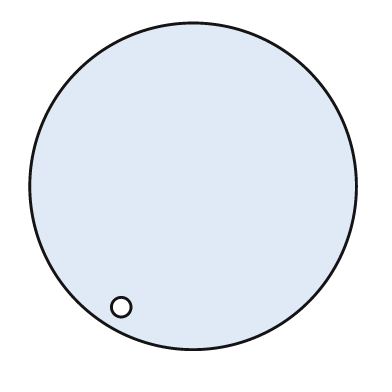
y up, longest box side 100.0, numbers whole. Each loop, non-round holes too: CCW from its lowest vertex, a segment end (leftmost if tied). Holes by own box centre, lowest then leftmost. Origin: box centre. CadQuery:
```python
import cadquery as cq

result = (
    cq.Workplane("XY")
    .moveTo(0.0, 0.0)
    .circle(50.0)
    .moveTo(-22.0, -37.0)
    .circle(3.0)
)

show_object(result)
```